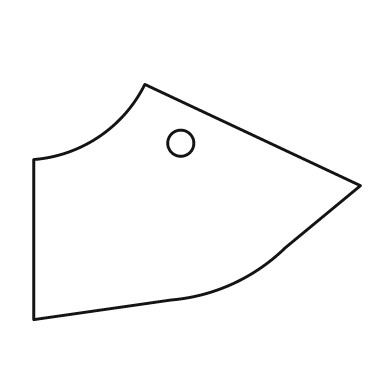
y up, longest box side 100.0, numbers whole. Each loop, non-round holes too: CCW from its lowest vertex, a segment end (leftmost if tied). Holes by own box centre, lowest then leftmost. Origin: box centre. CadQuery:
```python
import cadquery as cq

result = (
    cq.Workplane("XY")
    .moveTo(-50.0, -36.0)
    .lineTo(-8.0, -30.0)
    .threePointArc((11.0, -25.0), (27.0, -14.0))
    .lineTo(50.0, 5.0)
    .lineTo(-16.0, 36.0)
    .threePointArc((-30.0, 20.0), (-50.0, 13.0))
    .close()
    .moveTo(-5.0, 18.0)
    .circle(4.0)
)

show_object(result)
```